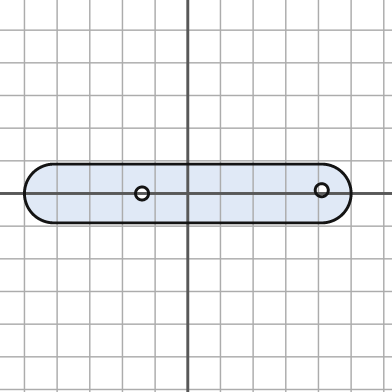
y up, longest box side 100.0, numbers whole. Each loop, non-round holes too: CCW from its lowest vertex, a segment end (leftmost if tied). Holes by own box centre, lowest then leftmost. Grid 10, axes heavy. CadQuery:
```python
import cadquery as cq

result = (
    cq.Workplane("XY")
    .moveTo(-41.0, -9.0)
    .lineTo(41.0, -9.0)
    .threePointArc((50.0, 0.0), (41.0, 9.0))
    .lineTo(-41.0, 9.0)
    .threePointArc((-50.0, 0.0), (-41.0, -9.0))
    .close()
    .moveTo(-14.0, 0.0)
    .circle(2.0)
    .moveTo(41.0, 1.0)
    .circle(2.0)
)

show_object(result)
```